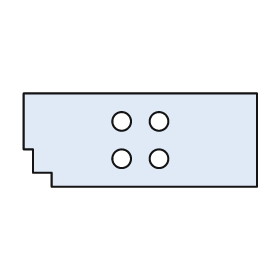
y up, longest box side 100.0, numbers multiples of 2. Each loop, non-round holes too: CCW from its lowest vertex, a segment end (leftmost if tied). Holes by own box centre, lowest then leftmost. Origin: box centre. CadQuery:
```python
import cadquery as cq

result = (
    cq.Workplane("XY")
    .moveTo(-38.0, -20.0)
    .lineTo(50.0, -20.0)
    .lineTo(50.0, 20.0)
    .lineTo(-50.0, 20.0)
    .lineTo(-50.0, -4.0)
    .lineTo(-46.0, -4.0)
    .lineTo(-46.0, -14.0)
    .lineTo(-38.0, -14.0)
    .close()
    .moveTo(-8.0, -8.0)
    .circle(4.0)
    .moveTo(8.0, -8.0)
    .circle(4.0)
    .moveTo(-8.0, 8.0)
    .circle(4.0)
    .moveTo(8.0, 8.0)
    .circle(4.0)
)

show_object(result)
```